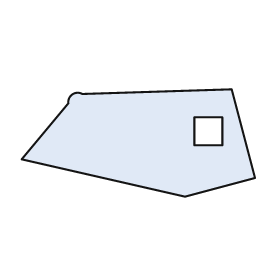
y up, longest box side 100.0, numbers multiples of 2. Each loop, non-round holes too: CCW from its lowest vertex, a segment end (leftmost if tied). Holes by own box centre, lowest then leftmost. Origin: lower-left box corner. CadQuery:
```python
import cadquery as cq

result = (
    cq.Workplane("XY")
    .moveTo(70.0, 0.0)
    .lineTo(100.0, 8.0)
    .lineTo(90.0, 46.0)
    .lineTo(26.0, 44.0)
    .threePointArc((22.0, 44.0), (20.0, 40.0))
    .lineTo(0.0, 16.0)
    .close()
    .moveTo(74.0, 22.0)
    .lineTo(86.0, 22.0)
    .lineTo(86.0, 34.0)
    .lineTo(74.0, 34.0)
    .close()
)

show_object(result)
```